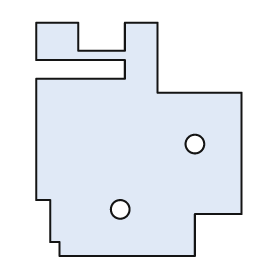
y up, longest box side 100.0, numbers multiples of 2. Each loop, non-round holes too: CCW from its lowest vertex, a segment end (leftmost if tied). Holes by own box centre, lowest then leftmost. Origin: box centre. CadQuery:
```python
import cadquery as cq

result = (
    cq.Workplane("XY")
    .moveTo(-34.0, -50.0)
    .lineTo(24.0, -50.0)
    .lineTo(24.0, -32.0)
    .lineTo(44.0, -32.0)
    .lineTo(44.0, 20.0)
    .lineTo(8.0, 20.0)
    .lineTo(8.0, 50.0)
    .lineTo(-6.0, 50.0)
    .lineTo(-6.0, 38.0)
    .lineTo(-26.0, 38.0)
    .lineTo(-26.0, 50.0)
    .lineTo(-44.0, 50.0)
    .lineTo(-44.0, 34.0)
    .lineTo(-6.0, 34.0)
    .lineTo(-6.0, 26.0)
    .lineTo(-44.0, 26.0)
    .lineTo(-44.0, -26.0)
    .lineTo(-38.0, -26.0)
    .lineTo(-38.0, -44.0)
    .lineTo(-34.0, -44.0)
    .close()
    .moveTo(-8.0, -30.0)
    .circle(4.0)
    .moveTo(24.0, -2.0)
    .circle(4.0)
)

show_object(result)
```